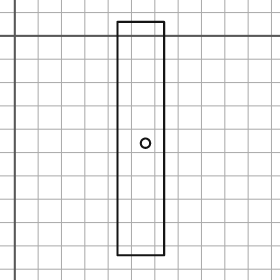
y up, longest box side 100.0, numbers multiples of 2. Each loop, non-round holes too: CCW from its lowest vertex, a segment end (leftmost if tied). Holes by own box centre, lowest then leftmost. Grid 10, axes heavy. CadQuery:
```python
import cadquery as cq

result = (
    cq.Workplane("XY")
    .moveTo(44.0, -94.0)
    .lineTo(64.0, -94.0)
    .lineTo(64.0, 6.0)
    .lineTo(44.0, 6.0)
    .close()
    .moveTo(56.0, -46.0)
    .circle(2.0)
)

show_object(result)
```